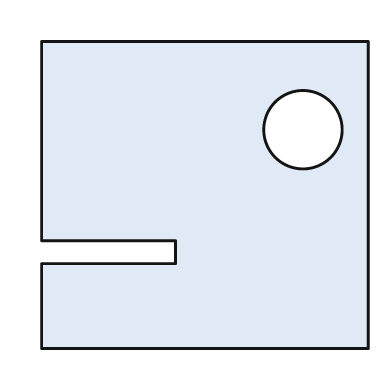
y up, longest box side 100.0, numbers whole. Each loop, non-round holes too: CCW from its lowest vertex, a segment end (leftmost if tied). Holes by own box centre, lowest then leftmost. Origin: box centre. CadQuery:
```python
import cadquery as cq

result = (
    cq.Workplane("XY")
    .moveTo(-50.0, -47.0)
    .lineTo(50.0, -47.0)
    .lineTo(50.0, 47.0)
    .lineTo(-50.0, 47.0)
    .lineTo(-50.0, -14.0)
    .lineTo(-9.0, -14.0)
    .lineTo(-9.0, -21.0)
    .lineTo(-50.0, -21.0)
    .close()
    .moveTo(30.0, 20.0)
    .circle(12.0)
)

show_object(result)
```